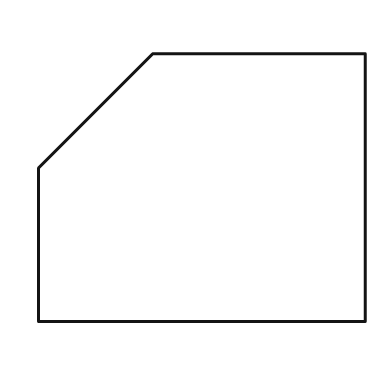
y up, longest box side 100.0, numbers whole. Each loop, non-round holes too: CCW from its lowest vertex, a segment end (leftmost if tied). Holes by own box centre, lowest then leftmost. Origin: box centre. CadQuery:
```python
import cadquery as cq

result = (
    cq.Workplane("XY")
    .moveTo(-50.0, -41.0)
    .lineTo(50.0, -41.0)
    .lineTo(50.0, 41.0)
    .lineTo(-15.0, 41.0)
    .lineTo(-50.0, 6.0)
    .close()
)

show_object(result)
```